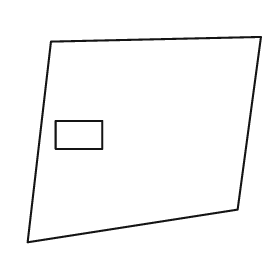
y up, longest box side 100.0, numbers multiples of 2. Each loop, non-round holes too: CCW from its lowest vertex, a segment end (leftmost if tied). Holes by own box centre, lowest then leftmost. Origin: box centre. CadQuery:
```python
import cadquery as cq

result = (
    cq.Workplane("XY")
    .moveTo(-50.0, -44.0)
    .lineTo(40.0, -30.0)
    .lineTo(50.0, 44.0)
    .lineTo(-40.0, 42.0)
    .close()
    .moveTo(-38.0, -4.0)
    .lineTo(-18.0, -4.0)
    .lineTo(-18.0, 8.0)
    .lineTo(-38.0, 8.0)
    .close()
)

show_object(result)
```